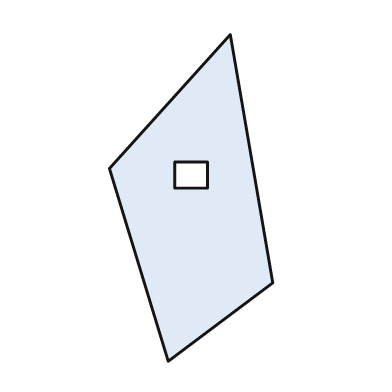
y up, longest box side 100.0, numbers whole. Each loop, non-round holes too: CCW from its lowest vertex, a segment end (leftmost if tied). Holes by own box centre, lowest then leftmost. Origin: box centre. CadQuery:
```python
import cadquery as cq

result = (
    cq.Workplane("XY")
    .moveTo(-7.0, -50.0)
    .lineTo(25.0, -26.0)
    .lineTo(12.0, 50.0)
    .lineTo(-25.0, 9.0)
    .close()
    .moveTo(-5.0, 3.0)
    .lineTo(5.0, 3.0)
    .lineTo(5.0, 11.0)
    .lineTo(-5.0, 11.0)
    .close()
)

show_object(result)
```